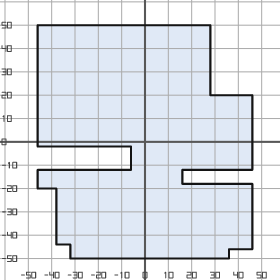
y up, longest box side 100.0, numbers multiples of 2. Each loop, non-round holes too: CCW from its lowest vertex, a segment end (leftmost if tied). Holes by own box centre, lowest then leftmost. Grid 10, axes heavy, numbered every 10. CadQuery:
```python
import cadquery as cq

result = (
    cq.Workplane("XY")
    .moveTo(-32.0, -50.0)
    .lineTo(36.0, -50.0)
    .lineTo(36.0, -46.0)
    .lineTo(46.0, -46.0)
    .lineTo(46.0, -18.0)
    .lineTo(16.0, -18.0)
    .lineTo(16.0, -12.0)
    .lineTo(46.0, -12.0)
    .lineTo(46.0, 20.0)
    .lineTo(28.0, 20.0)
    .lineTo(28.0, 50.0)
    .lineTo(-46.0, 50.0)
    .lineTo(-46.0, -2.0)
    .lineTo(-6.0, -2.0)
    .lineTo(-6.0, -12.0)
    .lineTo(-46.0, -12.0)
    .lineTo(-46.0, -20.0)
    .lineTo(-38.0, -20.0)
    .lineTo(-38.0, -44.0)
    .lineTo(-32.0, -44.0)
    .close()
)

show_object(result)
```